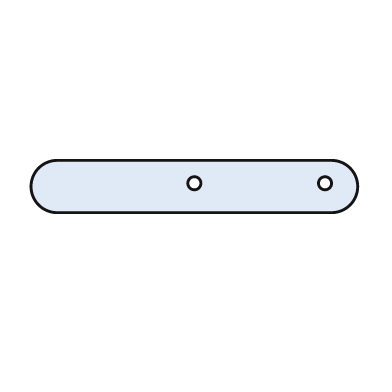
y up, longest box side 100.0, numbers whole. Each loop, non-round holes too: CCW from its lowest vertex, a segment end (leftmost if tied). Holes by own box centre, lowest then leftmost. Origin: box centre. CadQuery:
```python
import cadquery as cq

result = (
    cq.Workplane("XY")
    .moveTo(-42.0, -8.0)
    .lineTo(42.0, -8.0)
    .threePointArc((50.0, 0.0), (42.0, 8.0))
    .lineTo(-42.0, 8.0)
    .threePointArc((-50.0, 0.0), (-42.0, -8.0))
    .close()
    .moveTo(0.0, 1.0)
    .circle(2.0)
    .moveTo(40.0, 1.0)
    .circle(2.0)
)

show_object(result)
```